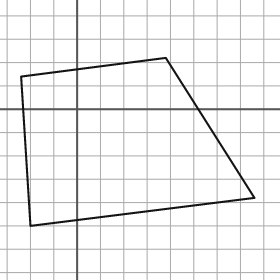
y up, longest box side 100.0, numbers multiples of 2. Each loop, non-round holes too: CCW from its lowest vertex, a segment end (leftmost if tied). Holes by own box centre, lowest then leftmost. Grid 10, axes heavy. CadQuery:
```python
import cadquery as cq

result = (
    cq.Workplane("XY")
    .moveTo(-20.0, -50.0)
    .lineTo(76.0, -38.0)
    .lineTo(38.0, 22.0)
    .lineTo(-24.0, 14.0)
    .close()
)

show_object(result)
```